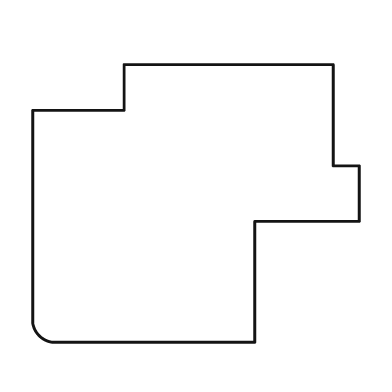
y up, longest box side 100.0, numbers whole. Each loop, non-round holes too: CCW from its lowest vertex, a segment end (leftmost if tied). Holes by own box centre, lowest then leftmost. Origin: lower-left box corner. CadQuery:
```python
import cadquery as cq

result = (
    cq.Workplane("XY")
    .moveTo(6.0, 0.0)
    .lineTo(68.0, 0.0)
    .lineTo(68.0, 37.0)
    .lineTo(100.0, 37.0)
    .lineTo(100.0, 54.0)
    .lineTo(92.0, 54.0)
    .lineTo(92.0, 85.0)
    .lineTo(28.0, 85.0)
    .lineTo(28.0, 71.0)
    .lineTo(0.0, 71.0)
    .lineTo(0.0, 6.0)
    .threePointArc((2.0, 2.0), (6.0, 0.0))
    .close()
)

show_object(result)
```